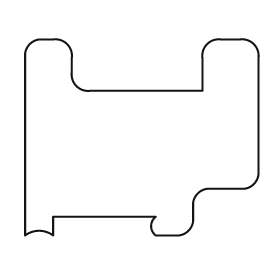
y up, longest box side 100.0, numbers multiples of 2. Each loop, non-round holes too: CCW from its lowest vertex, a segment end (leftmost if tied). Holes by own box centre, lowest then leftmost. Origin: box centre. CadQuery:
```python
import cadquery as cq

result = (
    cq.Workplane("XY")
    .moveTo(-50.0, -42.0)
    .threePointArc((-44.0, -40.0), (-38.0, -42.0))
    .lineTo(-38.0, -34.0)
    .lineTo(6.0, -34.0)
    .threePointArc((4.0, -38.0), (6.0, -42.0))
    .lineTo(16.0, -42.0)
    .threePointArc((20.0, -40.0), (22.0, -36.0))
    .lineTo(22.0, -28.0)
    .threePointArc((24.0, -24.0), (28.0, -22.0))
    .lineTo(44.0, -22.0)
    .threePointArc((48.0, -20.0), (50.0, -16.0))
    .lineTo(50.0, 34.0)
    .threePointArc((48.0, 40.0), (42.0, 42.0))
    .lineTo(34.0, 42.0)
    .threePointArc((28.0, 40.0), (26.0, 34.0))
    .lineTo(26.0, 20.0)
    .lineTo(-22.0, 20.0)
    .threePointArc((-28.0, 22.0), (-30.0, 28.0))
    .lineTo(-30.0, 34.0)
    .threePointArc((-32.0, 40.0), (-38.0, 42.0))
    .lineTo(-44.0, 42.0)
    .threePointArc((-48.0, 40.0), (-50.0, 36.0))
    .close()
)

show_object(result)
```